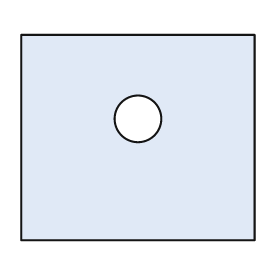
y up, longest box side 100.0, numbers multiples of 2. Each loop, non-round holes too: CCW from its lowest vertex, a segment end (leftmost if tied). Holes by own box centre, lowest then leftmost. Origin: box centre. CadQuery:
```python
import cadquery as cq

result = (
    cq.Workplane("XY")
    .moveTo(-50.0, -44.0)
    .lineTo(50.0, -44.0)
    .lineTo(50.0, 44.0)
    .lineTo(-50.0, 44.0)
    .close()
    .moveTo(0.0, 8.0)
    .circle(10.0)
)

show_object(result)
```